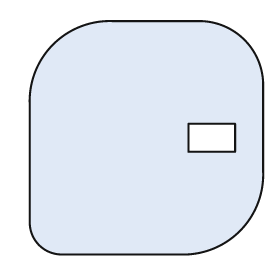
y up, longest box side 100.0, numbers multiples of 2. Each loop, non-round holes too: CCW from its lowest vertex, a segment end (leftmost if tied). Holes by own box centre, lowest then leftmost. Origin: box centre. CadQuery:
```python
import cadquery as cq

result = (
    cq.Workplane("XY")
    .moveTo(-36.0, -50.0)
    .lineTo(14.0, -50.0)
    .threePointArc((40.0, -40.0), (50.0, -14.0))
    .lineTo(50.0, 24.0)
    .threePointArc((42.0, 42.0), (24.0, 50.0))
    .lineTo(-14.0, 50.0)
    .threePointArc((-40.0, 40.0), (-50.0, 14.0))
    .lineTo(-50.0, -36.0)
    .threePointArc((-46.0, -46.0), (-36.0, -50.0))
    .close()
    .moveTo(18.0, -6.0)
    .lineTo(38.0, -6.0)
    .lineTo(38.0, 6.0)
    .lineTo(18.0, 6.0)
    .close()
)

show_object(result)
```